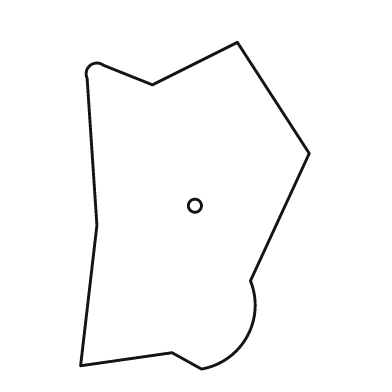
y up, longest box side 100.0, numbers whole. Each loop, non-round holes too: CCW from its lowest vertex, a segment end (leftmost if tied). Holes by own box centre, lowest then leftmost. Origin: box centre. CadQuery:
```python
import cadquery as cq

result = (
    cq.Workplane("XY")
    .moveTo(2.0, -50.0)
    .threePointArc((16.0, -40.0), (17.0, -23.0))
    .lineTo(35.0, 16.0)
    .lineTo(13.0, 50.0)
    .lineTo(-13.0, 37.0)
    .lineTo(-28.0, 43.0)
    .threePointArc((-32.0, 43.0), (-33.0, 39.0))
    .lineTo(-30.0, -6.0)
    .lineTo(-35.0, -49.0)
    .lineTo(-7.0, -45.0)
    .close()
    .moveTo(0.0, 0.0)
    .circle(2.0)
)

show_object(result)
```